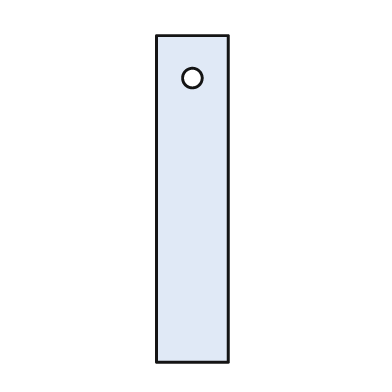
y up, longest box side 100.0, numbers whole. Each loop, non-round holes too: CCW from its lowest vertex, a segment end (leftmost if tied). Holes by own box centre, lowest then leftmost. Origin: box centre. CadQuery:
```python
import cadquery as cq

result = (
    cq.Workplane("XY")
    .moveTo(-11.0, -50.0)
    .lineTo(11.0, -50.0)
    .lineTo(11.0, 50.0)
    .lineTo(-11.0, 50.0)
    .close()
    .moveTo(0.0, 37.0)
    .circle(3.0)
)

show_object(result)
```